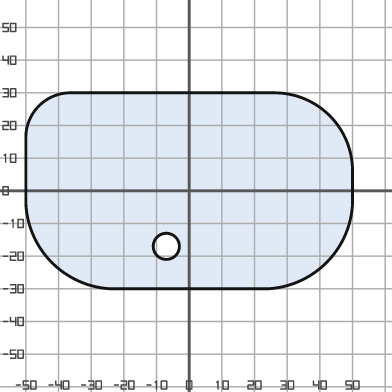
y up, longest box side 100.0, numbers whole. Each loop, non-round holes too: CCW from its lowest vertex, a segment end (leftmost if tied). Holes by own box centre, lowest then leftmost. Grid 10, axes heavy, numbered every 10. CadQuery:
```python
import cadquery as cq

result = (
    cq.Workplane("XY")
    .moveTo(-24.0, -30.0)
    .lineTo(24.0, -30.0)
    .threePointArc((42.0, -22.0), (50.0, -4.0))
    .lineTo(50.0, 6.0)
    .threePointArc((43.0, 23.0), (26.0, 30.0))
    .lineTo(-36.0, 30.0)
    .threePointArc((-46.0, 26.0), (-50.0, 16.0))
    .lineTo(-50.0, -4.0)
    .threePointArc((-42.0, -22.0), (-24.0, -30.0))
    .close()
    .moveTo(-7.0, -17.0)
    .circle(4.0)
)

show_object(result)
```